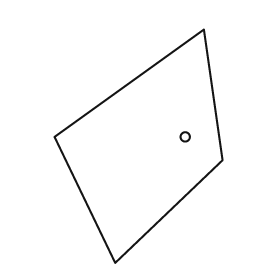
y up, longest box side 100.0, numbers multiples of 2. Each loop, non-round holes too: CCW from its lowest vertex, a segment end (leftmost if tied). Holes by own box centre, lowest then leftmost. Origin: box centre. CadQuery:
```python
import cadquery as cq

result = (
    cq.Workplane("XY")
    .moveTo(-10.0, -50.0)
    .lineTo(36.0, -6.0)
    .lineTo(28.0, 50.0)
    .lineTo(-36.0, 4.0)
    .close()
    .moveTo(20.0, 4.0)
    .circle(2.0)
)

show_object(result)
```